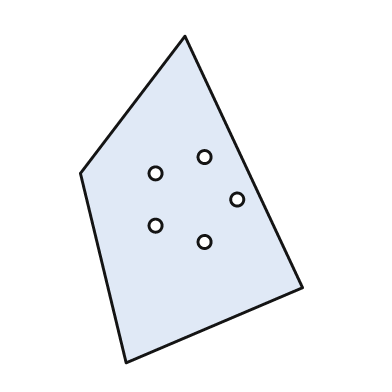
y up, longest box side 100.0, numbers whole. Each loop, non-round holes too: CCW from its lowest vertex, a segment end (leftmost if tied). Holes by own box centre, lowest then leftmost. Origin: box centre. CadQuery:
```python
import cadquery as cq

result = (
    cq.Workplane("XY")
    .moveTo(-20.0, -50.0)
    .lineTo(34.0, -27.0)
    .lineTo(-2.0, 50.0)
    .lineTo(-34.0, 8.0)
    .close()
    .moveTo(4.0, -13.0)
    .circle(2.0)
    .moveTo(-11.0, -8.0)
    .circle(2.0)
    .moveTo(14.0, 0.0)
    .circle(2.0)
    .moveTo(-11.0, 8.0)
    .circle(2.0)
    .moveTo(4.0, 13.0)
    .circle(2.0)
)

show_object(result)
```